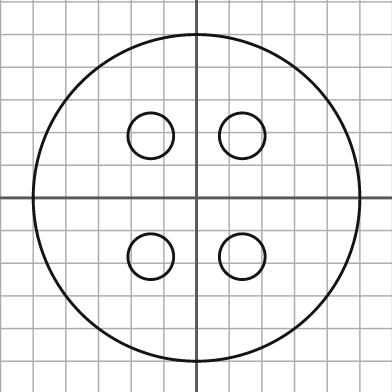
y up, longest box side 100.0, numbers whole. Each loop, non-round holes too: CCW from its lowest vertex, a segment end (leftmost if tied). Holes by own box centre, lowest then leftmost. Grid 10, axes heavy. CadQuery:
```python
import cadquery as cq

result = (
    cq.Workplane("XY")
    .moveTo(0.0, 0.0)
    .circle(50.0)
    .moveTo(-14.0, -18.0)
    .circle(7.0)
    .moveTo(14.0, -18.0)
    .circle(7.0)
    .moveTo(-14.0, 19.0)
    .circle(7.0)
    .moveTo(14.0, 19.0)
    .circle(7.0)
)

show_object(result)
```